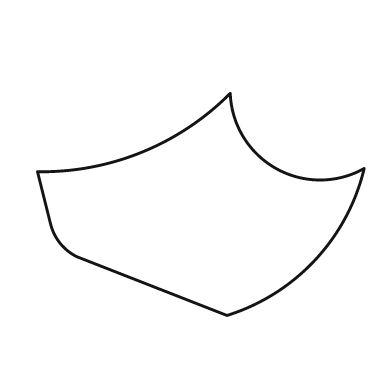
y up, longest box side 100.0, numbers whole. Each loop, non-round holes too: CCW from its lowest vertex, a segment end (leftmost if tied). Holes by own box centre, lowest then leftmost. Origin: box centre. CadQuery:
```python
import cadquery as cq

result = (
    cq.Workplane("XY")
    .moveTo(8.0, -34.0)
    .threePointArc((35.0, -17.0), (50.0, 11.0))
    .threePointArc((23.0, 11.0), (9.0, 34.0))
    .threePointArc((-18.0, 16.0), (-50.0, 10.0))
    .lineTo(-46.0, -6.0)
    .threePointArc((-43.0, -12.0), (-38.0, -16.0))
    .close()
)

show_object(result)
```